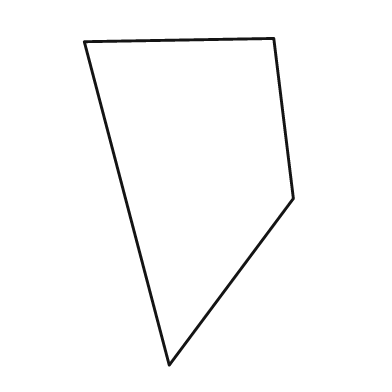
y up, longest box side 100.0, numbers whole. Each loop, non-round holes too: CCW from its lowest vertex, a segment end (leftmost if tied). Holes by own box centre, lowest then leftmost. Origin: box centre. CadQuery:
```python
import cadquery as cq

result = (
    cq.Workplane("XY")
    .moveTo(-6.0, -50.0)
    .lineTo(32.0, 1.0)
    .lineTo(26.0, 50.0)
    .lineTo(-32.0, 49.0)
    .close()
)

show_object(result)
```